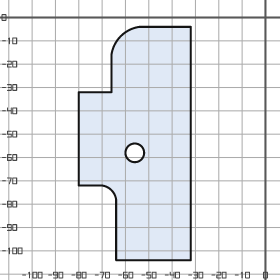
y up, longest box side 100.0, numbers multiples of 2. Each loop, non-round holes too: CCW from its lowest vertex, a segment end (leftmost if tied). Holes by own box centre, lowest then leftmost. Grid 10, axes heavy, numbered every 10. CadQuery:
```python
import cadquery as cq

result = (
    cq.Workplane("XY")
    .moveTo(-64.0, -104.0)
    .lineTo(-32.0, -104.0)
    .lineTo(-32.0, -4.0)
    .lineTo(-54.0, -4.0)
    .threePointArc((-62.0, -8.0), (-66.0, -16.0))
    .lineTo(-66.0, -32.0)
    .lineTo(-80.0, -32.0)
    .lineTo(-80.0, -72.0)
    .lineTo(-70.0, -72.0)
    .threePointArc((-66.0, -74.0), (-64.0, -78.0))
    .close()
    .moveTo(-56.0, -58.0)
    .circle(4.0)
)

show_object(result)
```